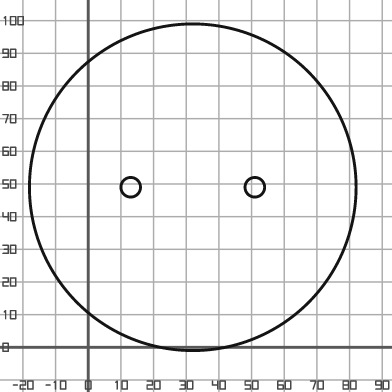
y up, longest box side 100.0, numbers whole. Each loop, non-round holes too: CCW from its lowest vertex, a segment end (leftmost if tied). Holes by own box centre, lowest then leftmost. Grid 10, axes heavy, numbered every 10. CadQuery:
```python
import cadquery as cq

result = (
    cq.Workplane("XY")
    .moveTo(32.0, 49.0)
    .circle(50.0)
    .moveTo(13.0, 49.0)
    .circle(3.0)
    .moveTo(51.0, 49.0)
    .circle(3.0)
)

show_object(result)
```